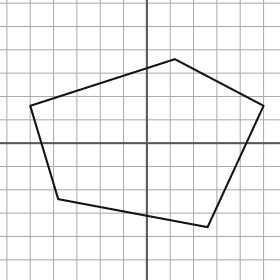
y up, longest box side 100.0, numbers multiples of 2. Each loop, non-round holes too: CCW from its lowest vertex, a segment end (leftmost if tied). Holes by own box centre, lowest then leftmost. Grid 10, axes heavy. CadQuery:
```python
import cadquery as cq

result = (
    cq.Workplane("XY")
    .moveTo(26.0, -36.0)
    .lineTo(50.0, 16.0)
    .lineTo(12.0, 36.0)
    .lineTo(-50.0, 16.0)
    .lineTo(-38.0, -24.0)
    .close()
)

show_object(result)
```